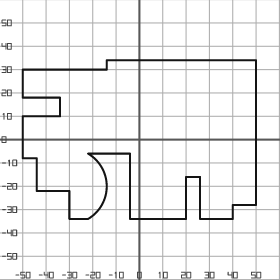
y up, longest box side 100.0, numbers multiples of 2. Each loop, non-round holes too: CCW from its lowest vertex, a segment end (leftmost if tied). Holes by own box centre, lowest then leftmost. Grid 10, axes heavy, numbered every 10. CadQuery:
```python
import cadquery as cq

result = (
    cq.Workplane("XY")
    .moveTo(-30.0, -34.0)
    .lineTo(-22.0, -34.0)
    .threePointArc((-14.0, -20.0), (-22.0, -6.0))
    .lineTo(-4.0, -6.0)
    .lineTo(-4.0, -34.0)
    .lineTo(20.0, -34.0)
    .lineTo(20.0, -16.0)
    .lineTo(26.0, -16.0)
    .lineTo(26.0, -34.0)
    .lineTo(40.0, -34.0)
    .lineTo(40.0, -28.0)
    .lineTo(50.0, -28.0)
    .lineTo(50.0, 34.0)
    .lineTo(-14.0, 34.0)
    .lineTo(-14.0, 30.0)
    .lineTo(-50.0, 30.0)
    .lineTo(-50.0, 18.0)
    .lineTo(-34.0, 18.0)
    .lineTo(-34.0, 10.0)
    .lineTo(-50.0, 10.0)
    .lineTo(-50.0, -8.0)
    .lineTo(-44.0, -8.0)
    .lineTo(-44.0, -22.0)
    .lineTo(-30.0, -22.0)
    .close()
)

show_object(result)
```